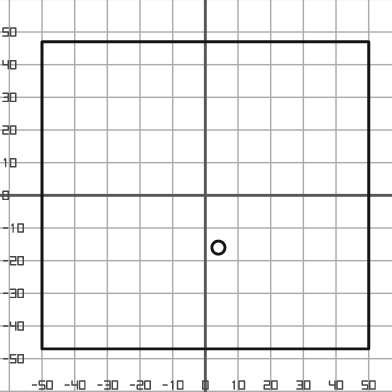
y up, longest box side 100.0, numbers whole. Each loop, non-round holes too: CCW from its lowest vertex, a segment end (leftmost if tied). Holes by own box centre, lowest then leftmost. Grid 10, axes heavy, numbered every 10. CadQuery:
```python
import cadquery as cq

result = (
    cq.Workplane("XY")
    .moveTo(-50.0, -47.0)
    .lineTo(50.0, -47.0)
    .lineTo(50.0, 47.0)
    .lineTo(-50.0, 47.0)
    .close()
    .moveTo(4.0, -16.0)
    .circle(2.0)
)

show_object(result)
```